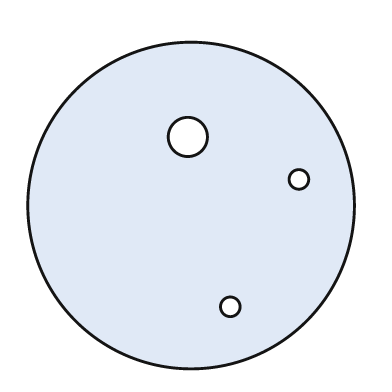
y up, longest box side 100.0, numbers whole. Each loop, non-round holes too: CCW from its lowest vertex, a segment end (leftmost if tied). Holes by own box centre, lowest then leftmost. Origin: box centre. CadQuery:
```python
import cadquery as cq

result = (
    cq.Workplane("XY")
    .moveTo(0.0, 0.0)
    .circle(50.0)
    .moveTo(12.0, -31.0)
    .circle(3.0)
    .moveTo(33.0, 8.0)
    .circle(3.0)
    .moveTo(-1.0, 21.0)
    .circle(6.0)
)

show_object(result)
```